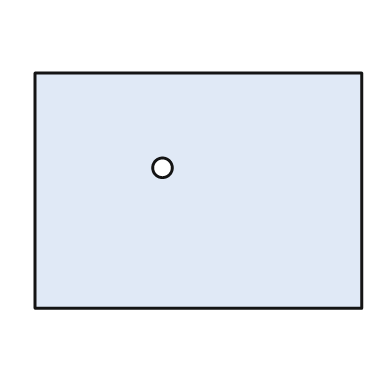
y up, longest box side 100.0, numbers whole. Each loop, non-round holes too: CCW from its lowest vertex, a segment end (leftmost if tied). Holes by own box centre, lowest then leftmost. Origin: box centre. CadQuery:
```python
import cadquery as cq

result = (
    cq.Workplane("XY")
    .moveTo(-50.0, -36.0)
    .lineTo(50.0, -36.0)
    .lineTo(50.0, 36.0)
    .lineTo(-50.0, 36.0)
    .close()
    .moveTo(-11.0, 7.0)
    .circle(3.0)
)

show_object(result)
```